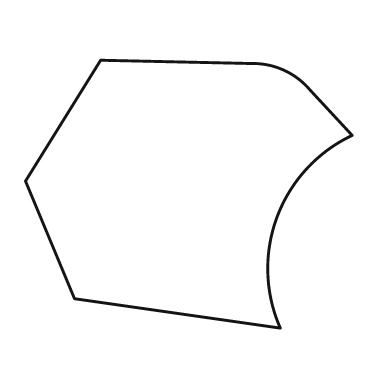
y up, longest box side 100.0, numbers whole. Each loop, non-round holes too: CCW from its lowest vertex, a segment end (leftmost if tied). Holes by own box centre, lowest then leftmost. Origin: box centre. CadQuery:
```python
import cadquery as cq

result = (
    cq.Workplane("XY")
    .moveTo(28.0, -41.0)
    .threePointArc((27.0, -7.0), (50.0, 18.0))
    .lineTo(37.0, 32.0)
    .threePointArc((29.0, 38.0), (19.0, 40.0))
    .lineTo(-27.0, 41.0)
    .lineTo(-50.0, 4.0)
    .lineTo(-35.0, -32.0)
    .close()
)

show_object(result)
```